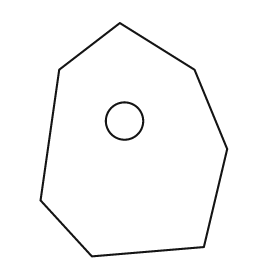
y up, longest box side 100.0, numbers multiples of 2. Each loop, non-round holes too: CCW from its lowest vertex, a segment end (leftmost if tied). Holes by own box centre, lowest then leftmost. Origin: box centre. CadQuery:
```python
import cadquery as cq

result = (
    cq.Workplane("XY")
    .moveTo(-18.0, -50.0)
    .lineTo(30.0, -46.0)
    .lineTo(40.0, -4.0)
    .lineTo(26.0, 30.0)
    .lineTo(-6.0, 50.0)
    .lineTo(-32.0, 30.0)
    .lineTo(-40.0, -26.0)
    .close()
    .moveTo(-4.0, 8.0)
    .circle(8.0)
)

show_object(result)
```